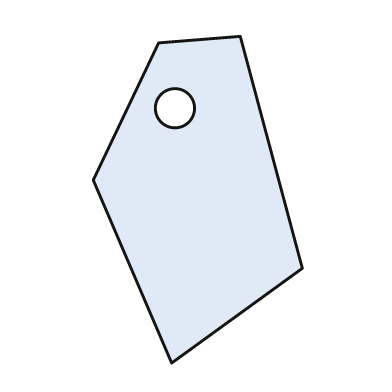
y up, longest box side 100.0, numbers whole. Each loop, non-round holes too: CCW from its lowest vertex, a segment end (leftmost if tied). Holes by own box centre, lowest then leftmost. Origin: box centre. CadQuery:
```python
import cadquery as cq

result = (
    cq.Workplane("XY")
    .moveTo(-8.0, -50.0)
    .lineTo(32.0, -21.0)
    .lineTo(13.0, 50.0)
    .lineTo(-12.0, 48.0)
    .lineTo(-32.0, 6.0)
    .close()
    .moveTo(-7.0, 28.0)
    .circle(6.0)
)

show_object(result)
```